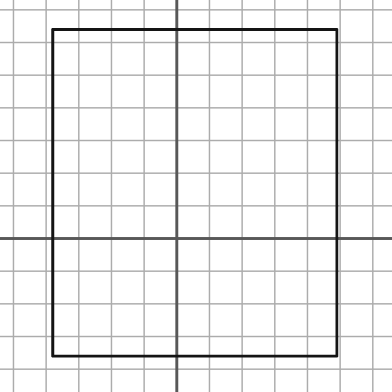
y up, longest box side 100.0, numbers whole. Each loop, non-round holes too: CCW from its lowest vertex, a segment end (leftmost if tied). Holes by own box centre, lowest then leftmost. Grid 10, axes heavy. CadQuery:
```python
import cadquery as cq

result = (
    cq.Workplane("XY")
    .moveTo(-38.0, -36.0)
    .lineTo(49.0, -36.0)
    .lineTo(49.0, 64.0)
    .lineTo(-38.0, 64.0)
    .close()
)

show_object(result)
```